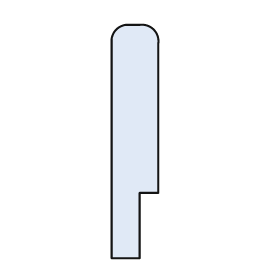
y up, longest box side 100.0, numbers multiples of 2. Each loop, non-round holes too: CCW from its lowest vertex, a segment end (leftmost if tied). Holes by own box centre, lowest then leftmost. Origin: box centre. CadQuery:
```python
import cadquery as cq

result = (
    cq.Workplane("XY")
    .moveTo(-10.0, -50.0)
    .lineTo(2.0, -50.0)
    .lineTo(2.0, -22.0)
    .lineTo(10.0, -22.0)
    .lineTo(10.0, 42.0)
    .threePointArc((8.0, 48.0), (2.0, 50.0))
    .lineTo(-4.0, 50.0)
    .threePointArc((-8.0, 48.0), (-10.0, 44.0))
    .close()
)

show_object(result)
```